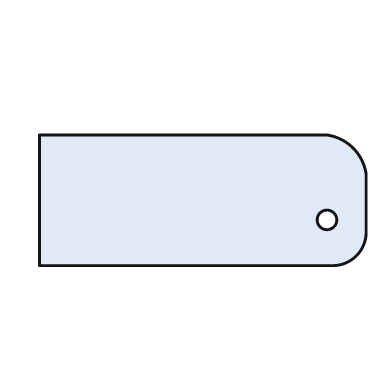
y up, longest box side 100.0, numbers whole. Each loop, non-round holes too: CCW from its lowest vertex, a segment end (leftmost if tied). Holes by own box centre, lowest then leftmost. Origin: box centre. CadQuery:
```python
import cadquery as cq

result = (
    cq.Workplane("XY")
    .moveTo(-50.0, -20.0)
    .lineTo(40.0, -20.0)
    .threePointArc((47.0, -17.0), (50.0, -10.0))
    .lineTo(50.0, 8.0)
    .threePointArc((46.0, 16.0), (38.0, 20.0))
    .lineTo(-50.0, 20.0)
    .close()
    .moveTo(38.0, -6.0)
    .circle(3.0)
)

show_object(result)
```